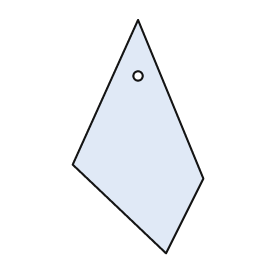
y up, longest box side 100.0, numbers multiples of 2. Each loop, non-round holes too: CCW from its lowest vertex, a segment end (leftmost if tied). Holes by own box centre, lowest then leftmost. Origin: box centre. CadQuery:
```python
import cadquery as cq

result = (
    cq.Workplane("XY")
    .moveTo(12.0, -50.0)
    .lineTo(28.0, -18.0)
    .lineTo(0.0, 50.0)
    .lineTo(-28.0, -12.0)
    .close()
    .moveTo(0.0, 26.0)
    .circle(2.0)
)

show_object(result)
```